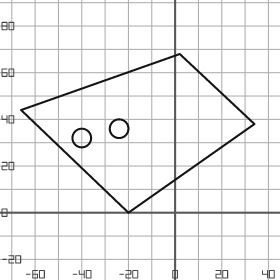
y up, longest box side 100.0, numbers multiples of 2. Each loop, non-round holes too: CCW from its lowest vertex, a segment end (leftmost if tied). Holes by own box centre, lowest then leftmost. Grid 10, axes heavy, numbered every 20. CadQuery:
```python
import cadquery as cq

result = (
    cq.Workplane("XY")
    .moveTo(-20.0, 0.0)
    .lineTo(34.0, 38.0)
    .lineTo(2.0, 68.0)
    .lineTo(-66.0, 44.0)
    .close()
    .moveTo(-40.0, 32.0)
    .circle(4.0)
    .moveTo(-24.0, 36.0)
    .circle(4.0)
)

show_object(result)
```